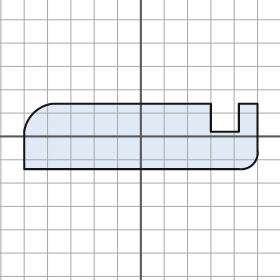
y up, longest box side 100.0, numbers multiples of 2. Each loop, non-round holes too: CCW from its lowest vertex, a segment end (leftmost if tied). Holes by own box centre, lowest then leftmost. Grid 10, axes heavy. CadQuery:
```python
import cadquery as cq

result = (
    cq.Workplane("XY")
    .moveTo(-50.0, -14.0)
    .lineTo(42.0, -14.0)
    .threePointArc((48.0, -12.0), (50.0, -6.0))
    .lineTo(50.0, 14.0)
    .lineTo(42.0, 14.0)
    .lineTo(42.0, 2.0)
    .lineTo(30.0, 2.0)
    .lineTo(30.0, 14.0)
    .lineTo(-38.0, 14.0)
    .threePointArc((-46.0, 10.0), (-50.0, 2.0))
    .close()
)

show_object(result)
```